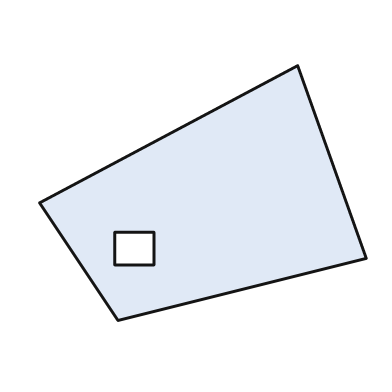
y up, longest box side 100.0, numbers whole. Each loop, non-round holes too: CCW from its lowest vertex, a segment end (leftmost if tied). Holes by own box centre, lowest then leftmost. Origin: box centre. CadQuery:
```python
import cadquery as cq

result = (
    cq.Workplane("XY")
    .moveTo(-26.0, -39.0)
    .lineTo(50.0, -20.0)
    .lineTo(29.0, 39.0)
    .lineTo(-50.0, -3.0)
    .close()
    .moveTo(-27.0, -22.0)
    .lineTo(-15.0, -22.0)
    .lineTo(-15.0, -12.0)
    .lineTo(-27.0, -12.0)
    .close()
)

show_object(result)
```